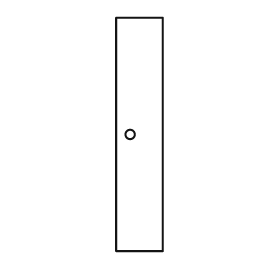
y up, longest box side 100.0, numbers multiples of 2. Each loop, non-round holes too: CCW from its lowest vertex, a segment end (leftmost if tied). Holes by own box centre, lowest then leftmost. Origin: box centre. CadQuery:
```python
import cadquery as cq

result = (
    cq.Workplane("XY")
    .moveTo(-10.0, -50.0)
    .lineTo(10.0, -50.0)
    .lineTo(10.0, 50.0)
    .lineTo(-10.0, 50.0)
    .close()
    .moveTo(-4.0, 0.0)
    .circle(2.0)
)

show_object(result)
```